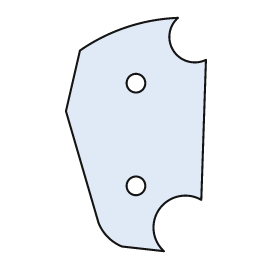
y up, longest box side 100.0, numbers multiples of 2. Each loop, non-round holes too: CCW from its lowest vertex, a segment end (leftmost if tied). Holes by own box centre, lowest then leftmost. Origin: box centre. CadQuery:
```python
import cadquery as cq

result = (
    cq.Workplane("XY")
    .moveTo(12.0, -50.0)
    .threePointArc((10.0, -32.0), (28.0, -28.0))
    .lineTo(30.0, 32.0)
    .threePointArc((16.0, 36.0), (18.0, 50.0))
    .threePointArc((-4.0, 46.0), (-24.0, 36.0))
    .lineTo(-30.0, 10.0)
    .lineTo(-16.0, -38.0)
    .threePointArc((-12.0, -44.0), (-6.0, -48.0))
    .close()
    .moveTo(0.0, -22.0)
    .circle(4.0)
    .moveTo(0.0, 22.0)
    .circle(4.0)
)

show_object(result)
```